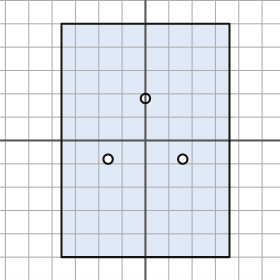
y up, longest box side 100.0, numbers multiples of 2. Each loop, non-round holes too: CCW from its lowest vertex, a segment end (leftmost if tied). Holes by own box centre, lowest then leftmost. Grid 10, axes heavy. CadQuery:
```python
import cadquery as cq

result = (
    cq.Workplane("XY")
    .moveTo(-36.0, -50.0)
    .lineTo(36.0, -50.0)
    .lineTo(36.0, 50.0)
    .lineTo(-36.0, 50.0)
    .close()
    .moveTo(-16.0, -8.0)
    .circle(2.0)
    .moveTo(16.0, -8.0)
    .circle(2.0)
    .moveTo(0.0, 18.0)
    .circle(2.0)
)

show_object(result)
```